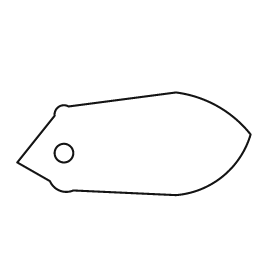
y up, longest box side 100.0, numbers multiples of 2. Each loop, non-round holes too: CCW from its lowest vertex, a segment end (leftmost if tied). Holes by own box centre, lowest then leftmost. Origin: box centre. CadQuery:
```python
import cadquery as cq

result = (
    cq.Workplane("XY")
    .moveTo(18.0, -22.0)
    .threePointArc((38.0, -14.0), (50.0, 4.0))
    .threePointArc((36.0, 16.0), (18.0, 22.0))
    .lineTo(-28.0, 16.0)
    .threePointArc((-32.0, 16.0), (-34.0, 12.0))
    .lineTo(-50.0, -8.0)
    .lineTo(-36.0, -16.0)
    .threePointArc((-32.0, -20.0), (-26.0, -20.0))
    .close()
    .moveTo(-30.0, -4.0)
    .circle(4.0)
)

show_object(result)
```